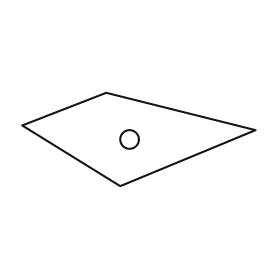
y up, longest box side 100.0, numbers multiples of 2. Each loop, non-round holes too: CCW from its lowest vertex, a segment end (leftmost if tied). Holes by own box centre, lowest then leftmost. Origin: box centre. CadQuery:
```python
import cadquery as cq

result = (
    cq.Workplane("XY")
    .moveTo(-8.0, -20.0)
    .lineTo(50.0, 4.0)
    .lineTo(-14.0, 20.0)
    .lineTo(-50.0, 6.0)
    .close()
    .moveTo(-4.0, 0.0)
    .circle(4.0)
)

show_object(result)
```